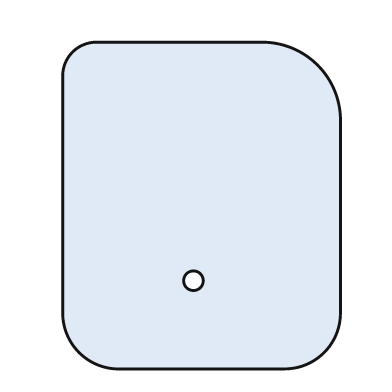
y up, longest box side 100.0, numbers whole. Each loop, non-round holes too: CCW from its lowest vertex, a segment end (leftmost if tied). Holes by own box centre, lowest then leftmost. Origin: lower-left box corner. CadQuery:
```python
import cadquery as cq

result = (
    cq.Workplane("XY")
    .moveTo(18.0, 0.0)
    .lineTo(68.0, 0.0)
    .threePointArc((80.0, 5.0), (85.0, 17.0))
    .lineTo(85.0, 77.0)
    .threePointArc((78.0, 93.0), (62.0, 100.0))
    .lineTo(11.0, 100.0)
    .threePointArc((3.0, 97.0), (0.0, 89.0))
    .lineTo(0.0, 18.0)
    .threePointArc((5.0, 5.0), (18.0, 0.0))
    .close()
    .moveTo(40.0, 27.0)
    .circle(3.0)
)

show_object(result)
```